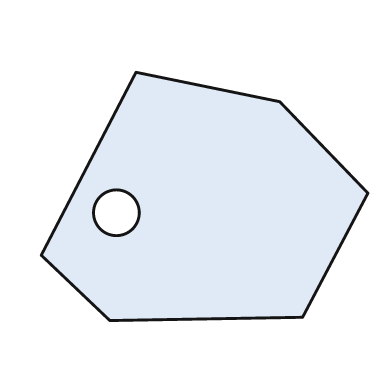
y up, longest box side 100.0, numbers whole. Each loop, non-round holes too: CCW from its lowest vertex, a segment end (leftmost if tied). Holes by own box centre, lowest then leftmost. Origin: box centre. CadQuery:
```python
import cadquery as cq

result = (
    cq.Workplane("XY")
    .moveTo(-29.0, -38.0)
    .lineTo(30.0, -37.0)
    .lineTo(50.0, 1.0)
    .lineTo(23.0, 29.0)
    .lineTo(-21.0, 38.0)
    .lineTo(-50.0, -18.0)
    .close()
    .moveTo(-27.0, -5.0)
    .circle(7.0)
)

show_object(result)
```